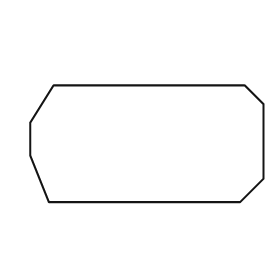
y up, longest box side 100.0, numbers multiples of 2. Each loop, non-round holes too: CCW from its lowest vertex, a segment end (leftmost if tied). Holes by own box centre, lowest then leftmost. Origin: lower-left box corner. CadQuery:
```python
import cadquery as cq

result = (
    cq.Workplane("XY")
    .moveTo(8.0, 0.0)
    .lineTo(90.0, 0.0)
    .lineTo(100.0, 10.0)
    .lineTo(100.0, 42.0)
    .lineTo(92.0, 50.0)
    .lineTo(10.0, 50.0)
    .lineTo(0.0, 34.0)
    .lineTo(0.0, 20.0)
    .close()
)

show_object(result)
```